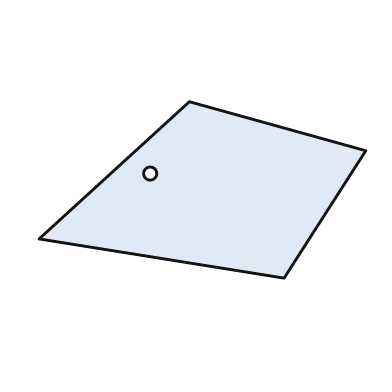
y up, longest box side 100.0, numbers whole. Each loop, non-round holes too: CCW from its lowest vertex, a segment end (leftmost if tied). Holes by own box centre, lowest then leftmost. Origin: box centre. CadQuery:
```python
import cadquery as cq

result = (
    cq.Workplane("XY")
    .moveTo(25.0, -27.0)
    .lineTo(50.0, 12.0)
    .lineTo(-4.0, 27.0)
    .lineTo(-50.0, -15.0)
    .close()
    .moveTo(-16.0, 5.0)
    .circle(2.0)
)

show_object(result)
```